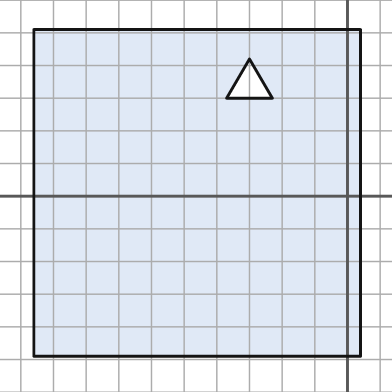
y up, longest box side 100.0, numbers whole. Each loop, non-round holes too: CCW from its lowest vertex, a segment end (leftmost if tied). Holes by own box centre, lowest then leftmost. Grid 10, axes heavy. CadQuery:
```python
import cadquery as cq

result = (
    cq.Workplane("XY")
    .moveTo(-96.0, -49.0)
    .lineTo(4.0, -49.0)
    .lineTo(4.0, 51.0)
    .lineTo(-96.0, 51.0)
    .close()
    .moveTo(-37.0, 30.0)
    .lineTo(-23.0, 30.0)
    .lineTo(-30.0, 42.0)
    .close()
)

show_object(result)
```